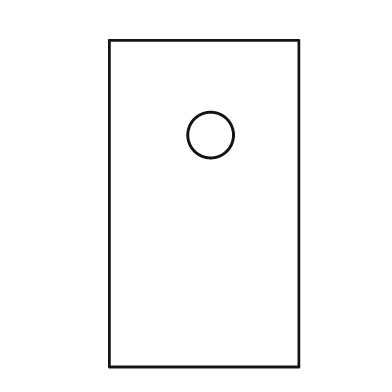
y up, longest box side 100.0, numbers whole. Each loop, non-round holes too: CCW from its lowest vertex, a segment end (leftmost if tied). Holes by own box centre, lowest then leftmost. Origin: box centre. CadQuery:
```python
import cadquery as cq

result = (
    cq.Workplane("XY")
    .moveTo(-29.0, -50.0)
    .lineTo(29.0, -50.0)
    .lineTo(29.0, 50.0)
    .lineTo(-29.0, 50.0)
    .close()
    .moveTo(2.0, 21.0)
    .circle(7.0)
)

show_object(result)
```